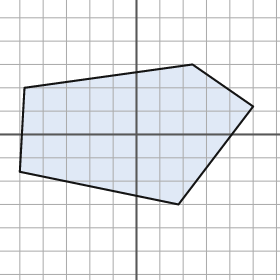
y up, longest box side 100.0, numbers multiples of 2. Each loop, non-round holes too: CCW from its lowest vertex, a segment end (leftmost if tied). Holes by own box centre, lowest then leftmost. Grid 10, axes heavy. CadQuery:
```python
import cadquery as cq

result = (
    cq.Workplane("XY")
    .moveTo(18.0, -30.0)
    .lineTo(50.0, 12.0)
    .lineTo(24.0, 30.0)
    .lineTo(-48.0, 20.0)
    .lineTo(-50.0, -16.0)
    .close()
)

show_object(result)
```